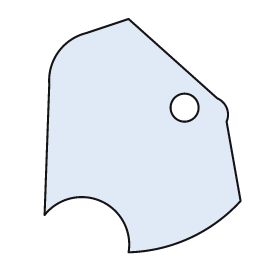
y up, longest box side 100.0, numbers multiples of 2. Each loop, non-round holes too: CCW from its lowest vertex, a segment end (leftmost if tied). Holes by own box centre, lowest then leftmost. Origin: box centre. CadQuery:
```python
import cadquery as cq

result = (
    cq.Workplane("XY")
    .moveTo(-6.0, -50.0)
    .threePointArc((20.0, -44.0), (42.0, -28.0))
    .lineTo(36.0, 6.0)
    .threePointArc((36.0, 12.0), (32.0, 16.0))
    .lineTo(-6.0, 50.0)
    .lineTo(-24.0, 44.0)
    .threePointArc((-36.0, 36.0), (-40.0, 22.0))
    .lineTo(-42.0, -34.0)
    .threePointArc((-18.0, -28.0), (-6.0, -50.0))
    .close()
    .moveTo(18.0, 12.0)
    .circle(6.0)
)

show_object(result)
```